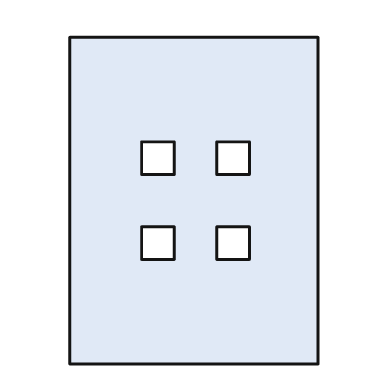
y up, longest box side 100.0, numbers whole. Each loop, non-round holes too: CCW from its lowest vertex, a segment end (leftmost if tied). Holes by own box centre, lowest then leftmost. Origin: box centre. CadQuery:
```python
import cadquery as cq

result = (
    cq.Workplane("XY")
    .moveTo(-38.0, -50.0)
    .lineTo(38.0, -50.0)
    .lineTo(38.0, 50.0)
    .lineTo(-38.0, 50.0)
    .close()
    .moveTo(-16.0, -18.0)
    .lineTo(-6.0, -18.0)
    .lineTo(-6.0, -8.0)
    .lineTo(-16.0, -8.0)
    .close()
    .moveTo(7.0, -18.0)
    .lineTo(17.0, -18.0)
    .lineTo(17.0, -8.0)
    .lineTo(7.0, -8.0)
    .close()
    .moveTo(-16.0, 8.0)
    .lineTo(-6.0, 8.0)
    .lineTo(-6.0, 18.0)
    .lineTo(-16.0, 18.0)
    .close()
    .moveTo(7.0, 8.0)
    .lineTo(17.0, 8.0)
    .lineTo(17.0, 18.0)
    .lineTo(7.0, 18.0)
    .close()
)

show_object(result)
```